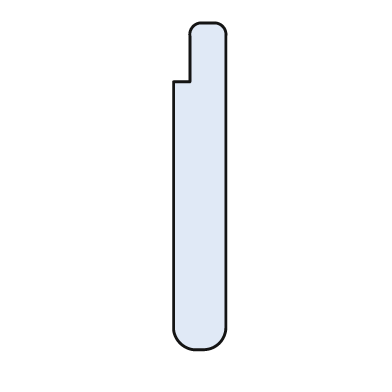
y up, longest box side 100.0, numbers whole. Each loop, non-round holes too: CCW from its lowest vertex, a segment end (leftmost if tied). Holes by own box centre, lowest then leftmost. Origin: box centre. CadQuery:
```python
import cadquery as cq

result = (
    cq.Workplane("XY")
    .moveTo(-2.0, -50.0)
    .lineTo(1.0, -50.0)
    .threePointArc((6.0, -48.0), (8.0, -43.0))
    .lineTo(8.0, 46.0)
    .threePointArc((7.0, 49.0), (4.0, 50.0))
    .lineTo(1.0, 50.0)
    .threePointArc((-2.0, 49.0), (-3.0, 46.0))
    .lineTo(-3.0, 32.0)
    .lineTo(-8.0, 32.0)
    .lineTo(-8.0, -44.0)
    .threePointArc((-6.0, -48.0), (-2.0, -50.0))
    .close()
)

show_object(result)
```